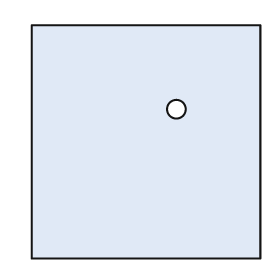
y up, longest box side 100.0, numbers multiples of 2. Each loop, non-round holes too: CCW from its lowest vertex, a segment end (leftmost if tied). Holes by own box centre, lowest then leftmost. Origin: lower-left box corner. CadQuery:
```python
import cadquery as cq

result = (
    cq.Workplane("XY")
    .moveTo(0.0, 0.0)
    .lineTo(98.0, 0.0)
    .lineTo(98.0, 100.0)
    .lineTo(0.0, 100.0)
    .close()
    .moveTo(62.0, 64.0)
    .circle(4.0)
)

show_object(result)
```